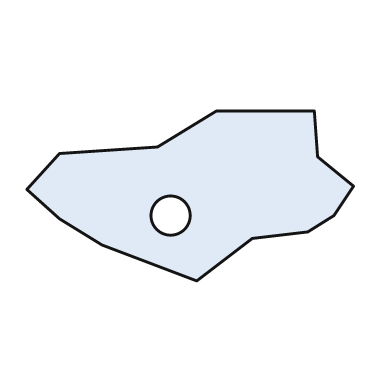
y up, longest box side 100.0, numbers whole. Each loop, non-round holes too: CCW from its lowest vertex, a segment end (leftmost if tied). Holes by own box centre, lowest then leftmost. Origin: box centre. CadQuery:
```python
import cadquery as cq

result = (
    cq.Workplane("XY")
    .moveTo(2.0, -26.0)
    .lineTo(19.0, -13.0)
    .lineTo(36.0, -11.0)
    .lineTo(44.0, -6.0)
    .lineTo(50.0, 3.0)
    .lineTo(39.0, 12.0)
    .lineTo(38.0, 26.0)
    .lineTo(8.0, 26.0)
    .lineTo(-10.0, 15.0)
    .lineTo(-40.0, 13.0)
    .lineTo(-50.0, 2.0)
    .lineTo(-40.0, -7.0)
    .lineTo(-27.0, -15.0)
    .close()
    .moveTo(-6.0, -6.0)
    .circle(6.0)
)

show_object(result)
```